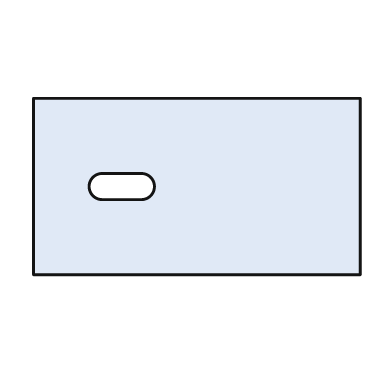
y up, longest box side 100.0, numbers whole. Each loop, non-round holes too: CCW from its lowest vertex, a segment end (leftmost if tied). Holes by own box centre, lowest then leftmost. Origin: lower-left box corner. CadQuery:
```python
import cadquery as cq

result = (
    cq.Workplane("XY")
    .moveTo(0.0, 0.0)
    .lineTo(100.0, 0.0)
    .lineTo(100.0, 54.0)
    .lineTo(0.0, 54.0)
    .close()
    .moveTo(21.0, 23.0)
    .lineTo(33.0, 23.0)
    .threePointArc((37.0, 27.0), (33.0, 31.0))
    .lineTo(21.0, 31.0)
    .threePointArc((17.0, 27.0), (21.0, 23.0))
    .close()
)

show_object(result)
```